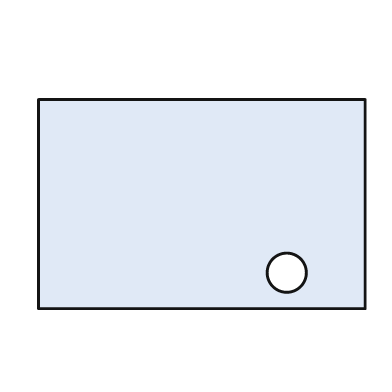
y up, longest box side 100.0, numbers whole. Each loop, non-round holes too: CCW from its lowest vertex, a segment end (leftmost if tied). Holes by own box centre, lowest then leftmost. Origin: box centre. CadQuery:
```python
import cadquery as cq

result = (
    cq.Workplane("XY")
    .moveTo(-50.0, -32.0)
    .lineTo(50.0, -32.0)
    .lineTo(50.0, 32.0)
    .lineTo(-50.0, 32.0)
    .close()
    .moveTo(26.0, -21.0)
    .circle(6.0)
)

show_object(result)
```